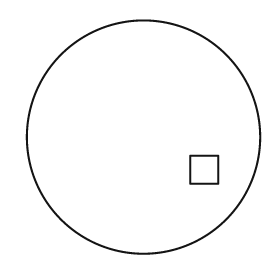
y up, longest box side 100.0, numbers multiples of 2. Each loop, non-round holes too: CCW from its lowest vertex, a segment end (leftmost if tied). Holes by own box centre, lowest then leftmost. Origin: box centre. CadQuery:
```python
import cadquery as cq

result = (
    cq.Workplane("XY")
    .moveTo(0.0, 0.0)
    .circle(50.0)
    .moveTo(20.0, -20.0)
    .lineTo(32.0, -20.0)
    .lineTo(32.0, -8.0)
    .lineTo(20.0, -8.0)
    .close()
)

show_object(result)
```